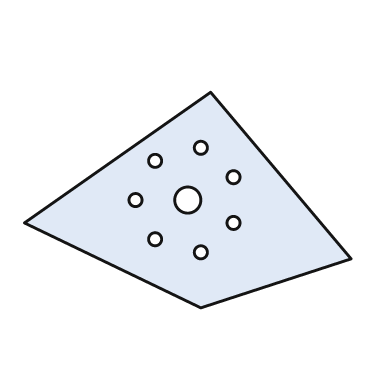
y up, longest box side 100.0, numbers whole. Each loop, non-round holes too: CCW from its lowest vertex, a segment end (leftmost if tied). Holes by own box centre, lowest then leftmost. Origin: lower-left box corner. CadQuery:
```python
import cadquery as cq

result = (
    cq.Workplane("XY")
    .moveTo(54.0, 0.0)
    .lineTo(100.0, 15.0)
    .lineTo(57.0, 66.0)
    .lineTo(0.0, 26.0)
    .close()
    .moveTo(54.0, 17.0)
    .circle(2.0)
    .moveTo(40.0, 21.0)
    .circle(2.0)
    .moveTo(64.0, 26.0)
    .circle(2.0)
    .moveTo(34.0, 33.0)
    .circle(2.0)
    .moveTo(50.0, 33.0)
    .circle(4.0)
    .moveTo(64.0, 40.0)
    .circle(2.0)
    .moveTo(40.0, 45.0)
    .circle(2.0)
    .moveTo(54.0, 49.0)
    .circle(2.0)
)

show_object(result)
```